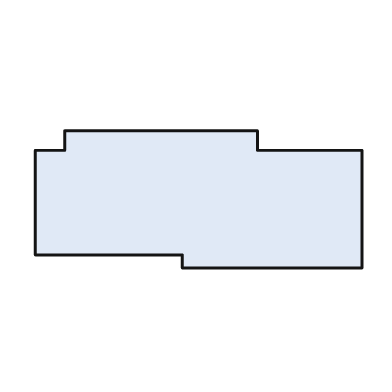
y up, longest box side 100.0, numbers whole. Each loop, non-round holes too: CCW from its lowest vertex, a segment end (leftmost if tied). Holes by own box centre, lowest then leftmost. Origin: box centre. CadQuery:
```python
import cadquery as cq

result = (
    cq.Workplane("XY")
    .moveTo(-5.0, -21.0)
    .lineTo(50.0, -21.0)
    .lineTo(50.0, 15.0)
    .lineTo(18.0, 15.0)
    .lineTo(18.0, 21.0)
    .lineTo(-41.0, 21.0)
    .lineTo(-41.0, 15.0)
    .lineTo(-50.0, 15.0)
    .lineTo(-50.0, -17.0)
    .lineTo(-5.0, -17.0)
    .close()
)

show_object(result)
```